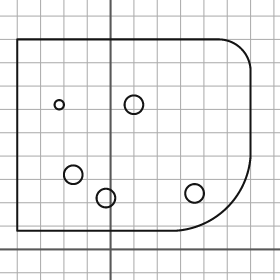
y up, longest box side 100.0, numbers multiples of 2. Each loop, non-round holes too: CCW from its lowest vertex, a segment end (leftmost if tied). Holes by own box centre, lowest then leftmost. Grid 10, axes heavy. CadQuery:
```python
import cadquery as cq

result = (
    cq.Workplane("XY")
    .moveTo(-40.0, 8.0)
    .lineTo(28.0, 8.0)
    .threePointArc((50.0, 18.0), (60.0, 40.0))
    .lineTo(60.0, 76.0)
    .threePointArc((56.0, 86.0), (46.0, 90.0))
    .lineTo(-40.0, 90.0)
    .close()
    .moveTo(-2.0, 22.0)
    .circle(4.0)
    .moveTo(36.0, 24.0)
    .circle(4.0)
    .moveTo(-16.0, 32.0)
    .circle(4.0)
    .moveTo(-22.0, 62.0)
    .circle(2.0)
    .moveTo(10.0, 62.0)
    .circle(4.0)
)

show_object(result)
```